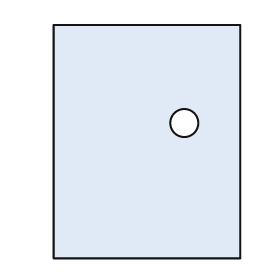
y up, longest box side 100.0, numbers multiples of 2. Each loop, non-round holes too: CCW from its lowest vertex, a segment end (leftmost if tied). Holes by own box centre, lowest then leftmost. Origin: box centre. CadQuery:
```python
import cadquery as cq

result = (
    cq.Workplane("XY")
    .moveTo(-40.0, -50.0)
    .lineTo(40.0, -50.0)
    .lineTo(40.0, 50.0)
    .lineTo(-40.0, 50.0)
    .close()
    .moveTo(16.0, 8.0)
    .circle(6.0)
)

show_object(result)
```